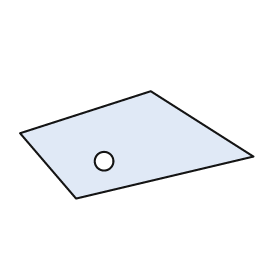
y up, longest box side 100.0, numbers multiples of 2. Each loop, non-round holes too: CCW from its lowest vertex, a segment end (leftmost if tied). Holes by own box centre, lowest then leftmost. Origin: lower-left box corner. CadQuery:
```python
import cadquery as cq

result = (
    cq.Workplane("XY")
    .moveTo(24.0, 0.0)
    .lineTo(100.0, 18.0)
    .lineTo(56.0, 46.0)
    .lineTo(0.0, 28.0)
    .close()
    .moveTo(36.0, 16.0)
    .circle(4.0)
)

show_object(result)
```